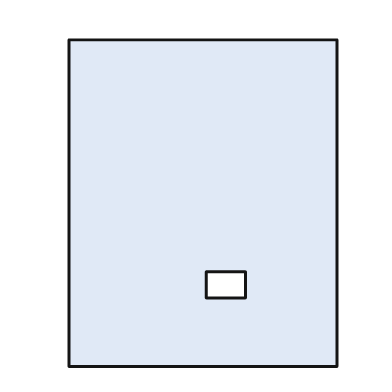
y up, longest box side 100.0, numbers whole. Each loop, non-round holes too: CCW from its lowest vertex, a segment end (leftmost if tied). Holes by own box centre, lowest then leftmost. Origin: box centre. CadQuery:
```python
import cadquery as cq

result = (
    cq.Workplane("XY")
    .moveTo(-41.0, -50.0)
    .lineTo(41.0, -50.0)
    .lineTo(41.0, 50.0)
    .lineTo(-41.0, 50.0)
    .close()
    .moveTo(1.0, -29.0)
    .lineTo(13.0, -29.0)
    .lineTo(13.0, -21.0)
    .lineTo(1.0, -21.0)
    .close()
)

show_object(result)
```